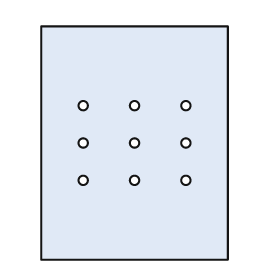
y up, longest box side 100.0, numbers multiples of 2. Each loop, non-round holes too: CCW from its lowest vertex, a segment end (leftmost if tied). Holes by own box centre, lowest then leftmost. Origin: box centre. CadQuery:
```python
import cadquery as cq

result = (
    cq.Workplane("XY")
    .moveTo(-40.0, -50.0)
    .lineTo(40.0, -50.0)
    .lineTo(40.0, 50.0)
    .lineTo(-40.0, 50.0)
    .close()
    .moveTo(-22.0, -16.0)
    .circle(2.0)
    .moveTo(0.0, -16.0)
    .circle(2.0)
    .moveTo(22.0, -16.0)
    .circle(2.0)
    .moveTo(-22.0, 0.0)
    .circle(2.0)
    .moveTo(0.0, 0.0)
    .circle(2.0)
    .moveTo(22.0, 0.0)
    .circle(2.0)
    .moveTo(-22.0, 16.0)
    .circle(2.0)
    .moveTo(0.0, 16.0)
    .circle(2.0)
    .moveTo(22.0, 16.0)
    .circle(2.0)
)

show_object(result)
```